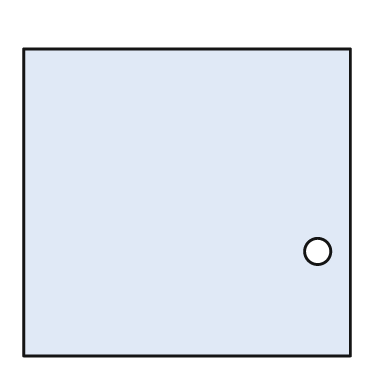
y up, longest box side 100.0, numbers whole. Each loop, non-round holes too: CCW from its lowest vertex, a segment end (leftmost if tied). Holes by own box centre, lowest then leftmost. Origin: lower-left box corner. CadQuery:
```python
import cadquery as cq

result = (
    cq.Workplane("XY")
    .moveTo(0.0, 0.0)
    .lineTo(100.0, 0.0)
    .lineTo(100.0, 94.0)
    .lineTo(0.0, 94.0)
    .close()
    .moveTo(90.0, 32.0)
    .circle(4.0)
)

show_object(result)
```